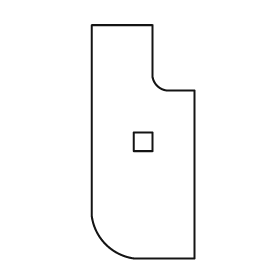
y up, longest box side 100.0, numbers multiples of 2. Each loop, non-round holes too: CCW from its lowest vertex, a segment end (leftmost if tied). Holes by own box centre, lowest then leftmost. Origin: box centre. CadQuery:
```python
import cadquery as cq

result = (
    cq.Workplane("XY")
    .moveTo(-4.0, -50.0)
    .lineTo(22.0, -50.0)
    .lineTo(22.0, 22.0)
    .lineTo(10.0, 22.0)
    .threePointArc((6.0, 24.0), (4.0, 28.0))
    .lineTo(4.0, 50.0)
    .lineTo(-22.0, 50.0)
    .lineTo(-22.0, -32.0)
    .threePointArc((-16.0, -44.0), (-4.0, -50.0))
    .close()
    .moveTo(-4.0, -4.0)
    .lineTo(4.0, -4.0)
    .lineTo(4.0, 4.0)
    .lineTo(-4.0, 4.0)
    .close()
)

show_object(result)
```